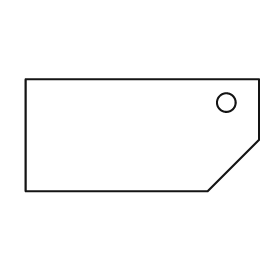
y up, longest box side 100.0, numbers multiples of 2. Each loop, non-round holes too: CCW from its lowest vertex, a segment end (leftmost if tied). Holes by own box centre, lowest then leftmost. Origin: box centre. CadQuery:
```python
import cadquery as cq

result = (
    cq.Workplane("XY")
    .moveTo(-50.0, -24.0)
    .lineTo(28.0, -24.0)
    .lineTo(50.0, -2.0)
    .lineTo(50.0, 24.0)
    .lineTo(-50.0, 24.0)
    .close()
    .moveTo(36.0, 14.0)
    .circle(4.0)
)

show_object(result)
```